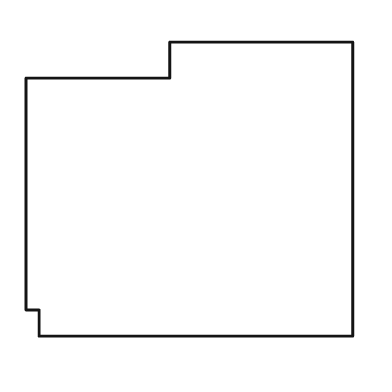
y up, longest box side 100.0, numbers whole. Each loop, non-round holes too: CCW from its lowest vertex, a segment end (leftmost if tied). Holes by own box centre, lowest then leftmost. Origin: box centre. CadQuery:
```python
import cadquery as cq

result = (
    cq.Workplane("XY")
    .moveTo(-46.0, -45.0)
    .lineTo(50.0, -45.0)
    .lineTo(50.0, 45.0)
    .lineTo(-6.0, 45.0)
    .lineTo(-6.0, 34.0)
    .lineTo(-50.0, 34.0)
    .lineTo(-50.0, -37.0)
    .lineTo(-46.0, -37.0)
    .close()
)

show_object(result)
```